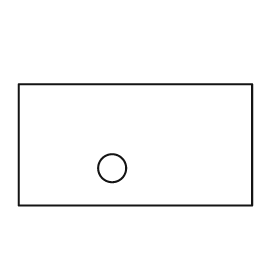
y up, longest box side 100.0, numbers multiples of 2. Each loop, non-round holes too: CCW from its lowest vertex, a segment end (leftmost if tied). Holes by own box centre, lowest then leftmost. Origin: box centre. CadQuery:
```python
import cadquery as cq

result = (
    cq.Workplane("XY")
    .moveTo(-50.0, -26.0)
    .lineTo(50.0, -26.0)
    .lineTo(50.0, 26.0)
    .lineTo(-50.0, 26.0)
    .close()
    .moveTo(-10.0, -10.0)
    .circle(6.0)
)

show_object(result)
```